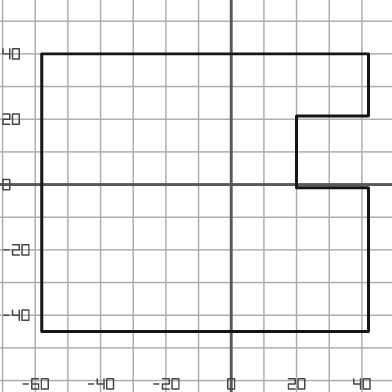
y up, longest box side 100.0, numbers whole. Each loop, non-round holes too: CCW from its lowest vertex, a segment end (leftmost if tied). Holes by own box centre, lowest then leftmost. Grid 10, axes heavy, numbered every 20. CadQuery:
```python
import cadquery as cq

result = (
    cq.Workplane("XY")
    .moveTo(-58.0, -45.0)
    .lineTo(42.0, -45.0)
    .lineTo(42.0, -1.0)
    .lineTo(20.0, -1.0)
    .lineTo(20.0, 21.0)
    .lineTo(42.0, 21.0)
    .lineTo(42.0, 40.0)
    .lineTo(-58.0, 40.0)
    .close()
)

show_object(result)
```